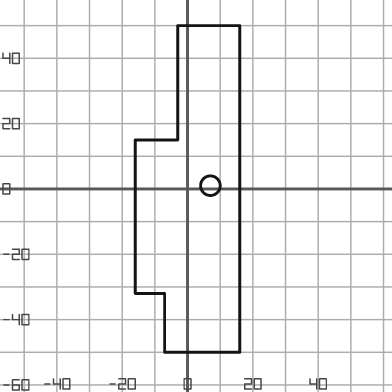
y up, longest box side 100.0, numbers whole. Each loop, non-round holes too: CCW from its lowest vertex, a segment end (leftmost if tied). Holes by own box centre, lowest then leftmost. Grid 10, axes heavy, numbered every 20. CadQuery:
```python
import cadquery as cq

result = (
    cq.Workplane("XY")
    .moveTo(-7.0, -50.0)
    .lineTo(16.0, -50.0)
    .lineTo(16.0, 50.0)
    .lineTo(-3.0, 50.0)
    .lineTo(-3.0, 15.0)
    .lineTo(-16.0, 15.0)
    .lineTo(-16.0, -32.0)
    .lineTo(-7.0, -32.0)
    .close()
    .moveTo(7.0, 1.0)
    .circle(3.0)
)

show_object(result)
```